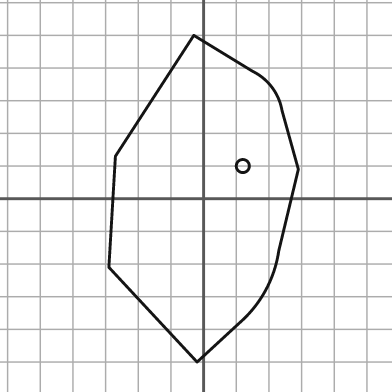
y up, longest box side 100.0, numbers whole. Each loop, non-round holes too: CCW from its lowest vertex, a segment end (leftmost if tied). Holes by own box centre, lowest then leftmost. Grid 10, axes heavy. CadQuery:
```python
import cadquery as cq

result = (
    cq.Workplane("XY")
    .moveTo(-2.0, -50.0)
    .lineTo(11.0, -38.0)
    .threePointArc((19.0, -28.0), (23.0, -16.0))
    .lineTo(29.0, 9.0)
    .lineTo(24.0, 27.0)
    .threePointArc((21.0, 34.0), (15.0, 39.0))
    .lineTo(-3.0, 50.0)
    .lineTo(-27.0, 13.0)
    .lineTo(-29.0, -21.0)
    .close()
    .moveTo(12.0, 10.0)
    .circle(2.0)
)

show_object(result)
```